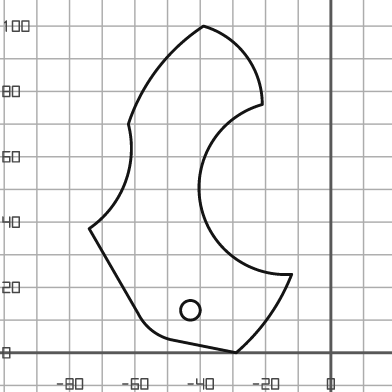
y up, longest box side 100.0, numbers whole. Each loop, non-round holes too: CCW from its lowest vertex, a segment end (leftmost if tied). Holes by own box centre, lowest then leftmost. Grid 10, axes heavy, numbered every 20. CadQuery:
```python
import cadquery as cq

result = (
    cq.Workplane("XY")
    .moveTo(-29.0, 0.0)
    .threePointArc((-19.0, 11.0), (-12.0, 24.0))
    .threePointArc((-40.0, 46.0), (-21.0, 76.0))
    .threePointArc((-26.0, 91.0), (-39.0, 100.0))
    .threePointArc((-53.0, 87.0), (-62.0, 70.0))
    .threePointArc((-63.0, 52.0), (-74.0, 38.0))
    .lineTo(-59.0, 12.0)
    .threePointArc((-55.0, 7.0), (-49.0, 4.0))
    .close()
    .moveTo(-43.0, 13.0)
    .circle(3.0)
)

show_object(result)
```